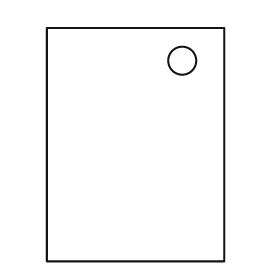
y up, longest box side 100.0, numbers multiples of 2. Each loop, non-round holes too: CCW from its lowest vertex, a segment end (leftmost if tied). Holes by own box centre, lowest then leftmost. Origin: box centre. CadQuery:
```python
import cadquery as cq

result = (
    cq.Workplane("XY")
    .moveTo(-38.0, -50.0)
    .lineTo(38.0, -50.0)
    .lineTo(38.0, 50.0)
    .lineTo(-38.0, 50.0)
    .close()
    .moveTo(20.0, 36.0)
    .circle(6.0)
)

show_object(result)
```